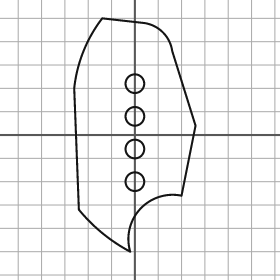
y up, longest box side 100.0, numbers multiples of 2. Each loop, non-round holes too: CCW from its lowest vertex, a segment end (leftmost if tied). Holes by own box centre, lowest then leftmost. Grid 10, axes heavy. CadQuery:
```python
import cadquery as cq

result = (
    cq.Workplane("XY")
    .moveTo(-2.0, -50.0)
    .threePointArc((2.0, -32.0), (20.0, -26.0))
    .lineTo(26.0, 4.0)
    .lineTo(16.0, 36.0)
    .threePointArc((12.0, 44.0), (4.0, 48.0))
    .lineTo(-14.0, 50.0)
    .threePointArc((-22.0, 36.0), (-26.0, 20.0))
    .lineTo(-24.0, -32.0)
    .threePointArc((-14.0, -42.0), (-2.0, -50.0))
    .close()
    .moveTo(0.0, -20.0)
    .circle(4.0)
    .moveTo(0.0, -6.0)
    .circle(4.0)
    .moveTo(0.0, 8.0)
    .circle(4.0)
    .moveTo(0.0, 22.0)
    .circle(4.0)
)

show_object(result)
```